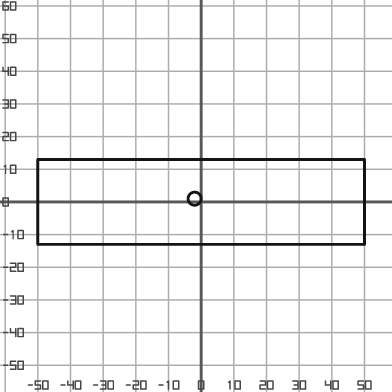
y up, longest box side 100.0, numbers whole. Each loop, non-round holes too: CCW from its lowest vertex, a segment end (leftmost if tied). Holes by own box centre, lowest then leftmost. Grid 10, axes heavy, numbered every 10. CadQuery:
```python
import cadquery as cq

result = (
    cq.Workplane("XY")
    .moveTo(-50.0, -13.0)
    .lineTo(50.0, -13.0)
    .lineTo(50.0, 13.0)
    .lineTo(-50.0, 13.0)
    .close()
    .moveTo(-2.0, 1.0)
    .circle(2.0)
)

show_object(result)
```